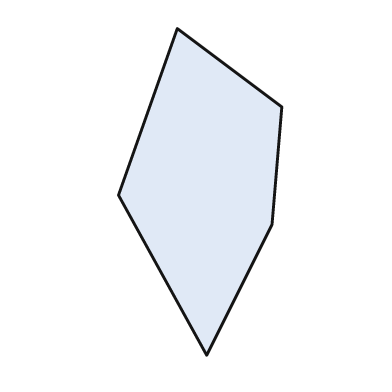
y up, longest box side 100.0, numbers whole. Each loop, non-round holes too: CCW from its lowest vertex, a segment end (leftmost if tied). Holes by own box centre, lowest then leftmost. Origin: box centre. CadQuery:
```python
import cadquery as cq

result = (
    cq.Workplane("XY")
    .moveTo(2.0, -50.0)
    .lineTo(22.0, -10.0)
    .lineTo(25.0, 26.0)
    .lineTo(-7.0, 50.0)
    .lineTo(-25.0, -1.0)
    .close()
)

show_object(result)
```